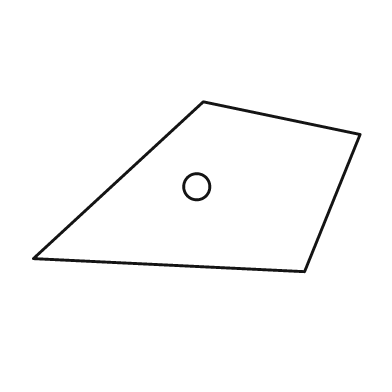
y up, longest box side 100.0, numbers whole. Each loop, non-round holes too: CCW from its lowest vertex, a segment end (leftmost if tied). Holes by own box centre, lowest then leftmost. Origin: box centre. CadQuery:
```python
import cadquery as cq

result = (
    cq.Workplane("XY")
    .moveTo(33.0, -26.0)
    .lineTo(50.0, 16.0)
    .lineTo(2.0, 26.0)
    .lineTo(-50.0, -22.0)
    .close()
    .moveTo(0.0, 0.0)
    .circle(4.0)
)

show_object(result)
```